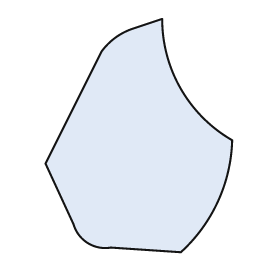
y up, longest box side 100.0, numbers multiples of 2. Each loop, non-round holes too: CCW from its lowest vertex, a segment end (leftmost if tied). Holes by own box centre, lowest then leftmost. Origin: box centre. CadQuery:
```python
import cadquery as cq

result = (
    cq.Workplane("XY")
    .moveTo(18.0, -50.0)
    .threePointArc((34.0, -28.0), (40.0, -2.0))
    .threePointArc((18.0, 20.0), (10.0, 50.0))
    .lineTo(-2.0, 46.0)
    .threePointArc((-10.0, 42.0), (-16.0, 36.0))
    .lineTo(-40.0, -12.0)
    .lineTo(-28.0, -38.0)
    .threePointArc((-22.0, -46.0), (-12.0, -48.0))
    .close()
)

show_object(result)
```